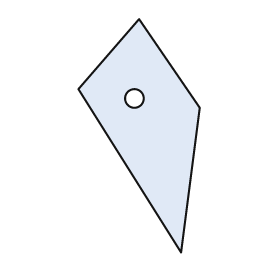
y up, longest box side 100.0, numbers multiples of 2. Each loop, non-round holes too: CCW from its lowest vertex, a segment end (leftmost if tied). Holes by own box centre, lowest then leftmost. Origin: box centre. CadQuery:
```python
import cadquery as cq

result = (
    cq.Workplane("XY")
    .moveTo(18.0, -50.0)
    .lineTo(26.0, 12.0)
    .lineTo(0.0, 50.0)
    .lineTo(-26.0, 20.0)
    .close()
    .moveTo(-2.0, 16.0)
    .circle(4.0)
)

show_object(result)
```